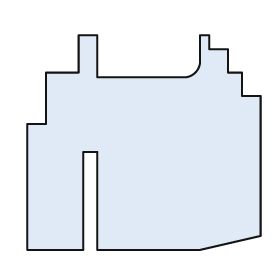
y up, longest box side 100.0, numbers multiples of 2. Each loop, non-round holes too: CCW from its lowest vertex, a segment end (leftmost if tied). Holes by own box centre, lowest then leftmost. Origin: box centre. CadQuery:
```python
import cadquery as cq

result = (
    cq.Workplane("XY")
    .moveTo(-50.0, -46.0)
    .lineTo(-26.0, -46.0)
    .lineTo(-26.0, -4.0)
    .lineTo(-20.0, -4.0)
    .lineTo(-20.0, -46.0)
    .lineTo(24.0, -46.0)
    .lineTo(50.0, -40.0)
    .lineTo(50.0, 20.0)
    .lineTo(42.0, 20.0)
    .lineTo(42.0, 30.0)
    .lineTo(36.0, 30.0)
    .lineTo(36.0, 40.0)
    .lineTo(28.0, 40.0)
    .lineTo(28.0, 46.0)
    .lineTo(24.0, 46.0)
    .lineTo(24.0, 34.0)
    .threePointArc((22.0, 30.0), (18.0, 28.0))
    .lineTo(-20.0, 28.0)
    .lineTo(-20.0, 46.0)
    .lineTo(-28.0, 46.0)
    .lineTo(-28.0, 30.0)
    .lineTo(-42.0, 30.0)
    .lineTo(-42.0, 8.0)
    .lineTo(-50.0, 8.0)
    .close()
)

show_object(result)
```